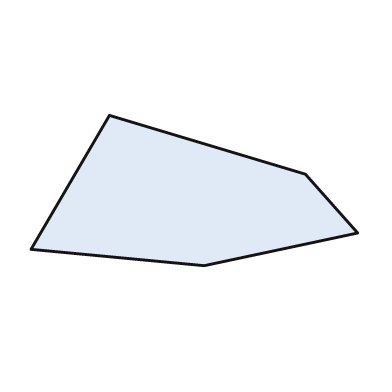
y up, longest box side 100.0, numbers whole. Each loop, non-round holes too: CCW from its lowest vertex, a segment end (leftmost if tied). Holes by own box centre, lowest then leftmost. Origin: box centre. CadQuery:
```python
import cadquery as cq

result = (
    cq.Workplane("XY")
    .moveTo(3.0, -23.0)
    .lineTo(50.0, -13.0)
    .lineTo(34.0, 5.0)
    .lineTo(-26.0, 23.0)
    .lineTo(-50.0, -18.0)
    .close()
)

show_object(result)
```